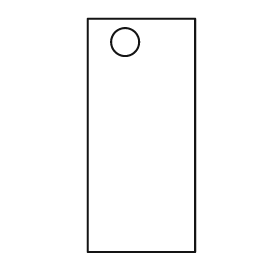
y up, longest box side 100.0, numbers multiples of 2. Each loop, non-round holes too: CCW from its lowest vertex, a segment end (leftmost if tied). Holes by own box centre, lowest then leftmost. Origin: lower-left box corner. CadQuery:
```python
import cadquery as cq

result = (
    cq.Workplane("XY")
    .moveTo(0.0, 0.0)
    .lineTo(46.0, 0.0)
    .lineTo(46.0, 100.0)
    .lineTo(0.0, 100.0)
    .close()
    .moveTo(16.0, 90.0)
    .circle(6.0)
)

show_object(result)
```